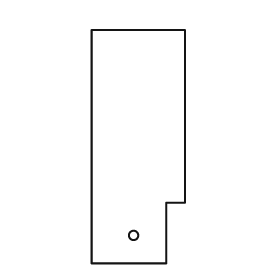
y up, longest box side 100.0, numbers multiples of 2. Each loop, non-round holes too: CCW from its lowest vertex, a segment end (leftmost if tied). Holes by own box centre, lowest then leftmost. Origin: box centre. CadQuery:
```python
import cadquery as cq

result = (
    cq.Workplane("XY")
    .moveTo(-20.0, -50.0)
    .lineTo(12.0, -50.0)
    .lineTo(12.0, -24.0)
    .lineTo(20.0, -24.0)
    .lineTo(20.0, 50.0)
    .lineTo(-20.0, 50.0)
    .close()
    .moveTo(-2.0, -38.0)
    .circle(2.0)
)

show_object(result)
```